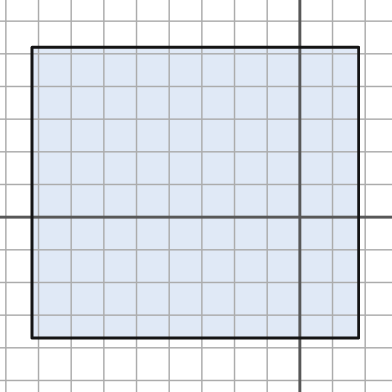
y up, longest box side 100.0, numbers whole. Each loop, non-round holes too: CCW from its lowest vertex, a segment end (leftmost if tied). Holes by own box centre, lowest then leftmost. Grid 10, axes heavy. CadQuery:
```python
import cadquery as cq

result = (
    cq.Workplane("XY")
    .moveTo(-82.0, -37.0)
    .lineTo(18.0, -37.0)
    .lineTo(18.0, 52.0)
    .lineTo(-82.0, 52.0)
    .close()
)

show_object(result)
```